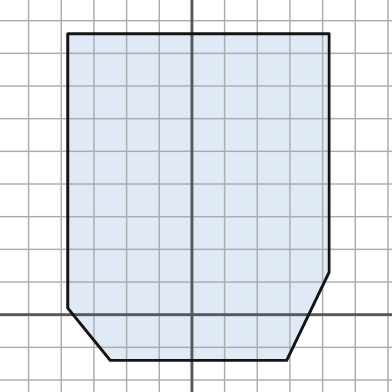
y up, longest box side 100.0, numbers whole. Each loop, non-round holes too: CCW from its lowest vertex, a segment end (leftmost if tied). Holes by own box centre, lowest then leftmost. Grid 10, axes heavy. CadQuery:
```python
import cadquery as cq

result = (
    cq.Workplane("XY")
    .moveTo(-25.0, -14.0)
    .lineTo(29.0, -14.0)
    .lineTo(42.0, 13.0)
    .lineTo(42.0, 86.0)
    .lineTo(-38.0, 86.0)
    .lineTo(-38.0, 2.0)
    .close()
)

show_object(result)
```